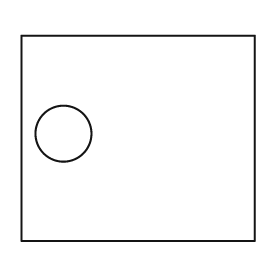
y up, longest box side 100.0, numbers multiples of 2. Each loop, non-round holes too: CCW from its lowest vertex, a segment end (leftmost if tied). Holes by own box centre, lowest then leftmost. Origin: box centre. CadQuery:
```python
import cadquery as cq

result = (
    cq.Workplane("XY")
    .moveTo(-50.0, -44.0)
    .lineTo(50.0, -44.0)
    .lineTo(50.0, 44.0)
    .lineTo(-50.0, 44.0)
    .close()
    .moveTo(-32.0, 2.0)
    .circle(12.0)
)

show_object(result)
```